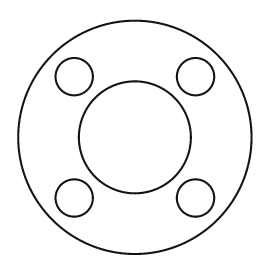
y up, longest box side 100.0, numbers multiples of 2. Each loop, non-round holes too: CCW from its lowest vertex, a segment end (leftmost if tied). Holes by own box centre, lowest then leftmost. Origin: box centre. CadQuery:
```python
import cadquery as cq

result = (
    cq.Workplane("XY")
    .moveTo(0.0, 0.0)
    .circle(50.0)
    .moveTo(-26.0, -26.0)
    .circle(8.0)
    .moveTo(26.0, -26.0)
    .circle(8.0)
    .moveTo(0.0, 0.0)
    .circle(24.0)
    .moveTo(-26.0, 26.0)
    .circle(8.0)
    .moveTo(26.0, 26.0)
    .circle(8.0)
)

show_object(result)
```